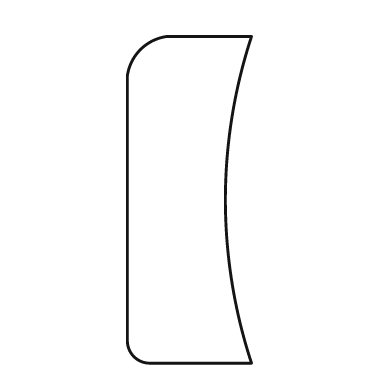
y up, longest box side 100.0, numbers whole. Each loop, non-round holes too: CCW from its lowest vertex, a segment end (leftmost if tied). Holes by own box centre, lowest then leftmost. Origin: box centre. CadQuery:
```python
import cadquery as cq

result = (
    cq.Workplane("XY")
    .moveTo(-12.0, -50.0)
    .lineTo(19.0, -50.0)
    .threePointArc((11.0, 0.0), (19.0, 50.0))
    .lineTo(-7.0, 50.0)
    .threePointArc((-15.0, 46.0), (-19.0, 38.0))
    .lineTo(-19.0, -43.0)
    .threePointArc((-17.0, -48.0), (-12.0, -50.0))
    .close()
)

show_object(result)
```